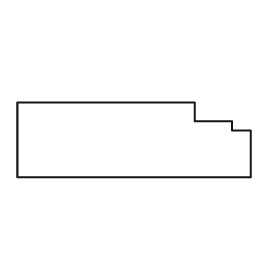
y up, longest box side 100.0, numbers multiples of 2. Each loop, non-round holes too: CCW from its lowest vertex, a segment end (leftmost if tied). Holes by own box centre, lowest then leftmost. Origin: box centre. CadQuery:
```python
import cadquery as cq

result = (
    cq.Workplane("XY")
    .moveTo(-50.0, -16.0)
    .lineTo(50.0, -16.0)
    .lineTo(50.0, 4.0)
    .lineTo(42.0, 4.0)
    .lineTo(42.0, 8.0)
    .lineTo(26.0, 8.0)
    .lineTo(26.0, 16.0)
    .lineTo(-50.0, 16.0)
    .close()
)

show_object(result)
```